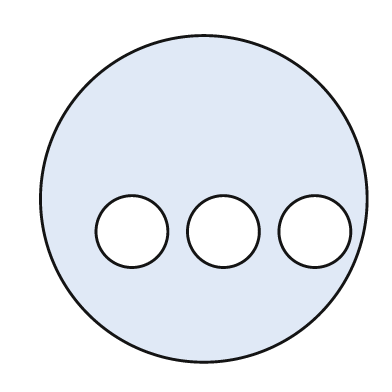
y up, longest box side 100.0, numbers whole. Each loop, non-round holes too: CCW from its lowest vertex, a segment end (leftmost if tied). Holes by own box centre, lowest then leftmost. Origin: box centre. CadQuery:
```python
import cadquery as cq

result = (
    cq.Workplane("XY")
    .moveTo(0.0, 0.0)
    .circle(50.0)
    .moveTo(-22.0, -10.0)
    .circle(11.0)
    .moveTo(6.0, -10.0)
    .circle(11.0)
    .moveTo(34.0, -10.0)
    .circle(11.0)
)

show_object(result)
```